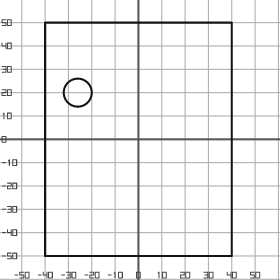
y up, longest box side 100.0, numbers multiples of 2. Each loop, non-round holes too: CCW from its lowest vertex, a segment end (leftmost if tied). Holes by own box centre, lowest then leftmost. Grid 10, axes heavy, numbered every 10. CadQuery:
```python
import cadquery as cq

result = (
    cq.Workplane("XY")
    .moveTo(-40.0, -50.0)
    .lineTo(40.0, -50.0)
    .lineTo(40.0, 50.0)
    .lineTo(-40.0, 50.0)
    .close()
    .moveTo(-26.0, 20.0)
    .circle(6.0)
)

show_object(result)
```